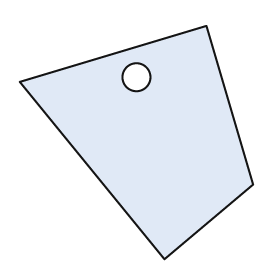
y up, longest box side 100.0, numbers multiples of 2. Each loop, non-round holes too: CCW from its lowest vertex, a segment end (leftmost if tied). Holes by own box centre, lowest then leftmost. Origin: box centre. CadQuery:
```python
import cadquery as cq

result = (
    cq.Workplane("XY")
    .moveTo(12.0, -50.0)
    .lineTo(50.0, -18.0)
    .lineTo(30.0, 50.0)
    .lineTo(-50.0, 26.0)
    .close()
    .moveTo(0.0, 28.0)
    .circle(6.0)
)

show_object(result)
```